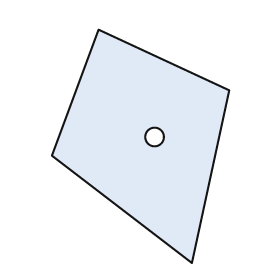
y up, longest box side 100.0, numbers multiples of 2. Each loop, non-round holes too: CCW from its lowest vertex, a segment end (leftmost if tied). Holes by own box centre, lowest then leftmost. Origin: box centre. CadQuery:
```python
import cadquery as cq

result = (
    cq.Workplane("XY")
    .moveTo(22.0, -50.0)
    .lineTo(38.0, 24.0)
    .lineTo(-18.0, 50.0)
    .lineTo(-38.0, -4.0)
    .close()
    .moveTo(6.0, 4.0)
    .circle(4.0)
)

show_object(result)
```